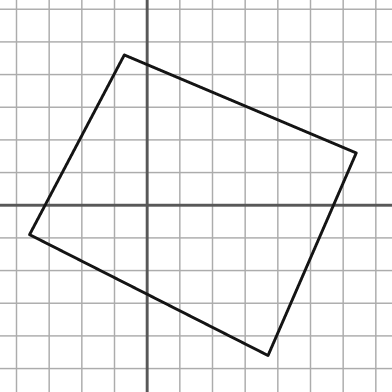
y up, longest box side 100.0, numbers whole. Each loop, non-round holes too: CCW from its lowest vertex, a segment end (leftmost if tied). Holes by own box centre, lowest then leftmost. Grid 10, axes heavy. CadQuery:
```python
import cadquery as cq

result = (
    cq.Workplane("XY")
    .moveTo(37.0, -46.0)
    .lineTo(64.0, 16.0)
    .lineTo(-7.0, 46.0)
    .lineTo(-36.0, -9.0)
    .close()
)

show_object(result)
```